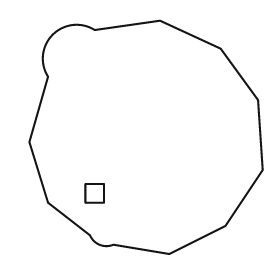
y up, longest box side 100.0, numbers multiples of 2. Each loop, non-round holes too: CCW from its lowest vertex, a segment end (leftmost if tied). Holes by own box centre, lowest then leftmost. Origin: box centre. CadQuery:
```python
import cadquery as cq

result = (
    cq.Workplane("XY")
    .moveTo(10.0, -50.0)
    .lineTo(34.0, -38.0)
    .lineTo(50.0, -14.0)
    .lineTo(48.0, 16.0)
    .lineTo(32.0, 38.0)
    .lineTo(6.0, 50.0)
    .lineTo(-22.0, 46.0)
    .threePointArc((-40.0, 44.0), (-42.0, 26.0))
    .lineTo(-50.0, -2.0)
    .lineTo(-42.0, -28.0)
    .lineTo(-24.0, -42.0)
    .threePointArc((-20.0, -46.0), (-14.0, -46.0))
    .close()
    .moveTo(-26.0, -28.0)
    .lineTo(-18.0, -28.0)
    .lineTo(-18.0, -20.0)
    .lineTo(-26.0, -20.0)
    .close()
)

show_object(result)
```